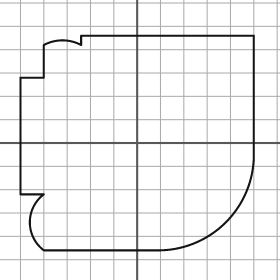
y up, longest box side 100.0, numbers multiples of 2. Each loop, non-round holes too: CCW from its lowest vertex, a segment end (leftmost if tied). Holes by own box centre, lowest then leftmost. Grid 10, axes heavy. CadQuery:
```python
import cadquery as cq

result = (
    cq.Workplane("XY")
    .moveTo(-40.0, -46.0)
    .lineTo(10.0, -46.0)
    .threePointArc((38.0, -34.0), (50.0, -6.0))
    .lineTo(50.0, 46.0)
    .lineTo(-24.0, 46.0)
    .lineTo(-24.0, 42.0)
    .threePointArc((-32.0, 44.0), (-40.0, 42.0))
    .lineTo(-40.0, 28.0)
    .lineTo(-50.0, 28.0)
    .lineTo(-50.0, -22.0)
    .lineTo(-40.0, -22.0)
    .threePointArc((-46.0, -34.0), (-40.0, -46.0))
    .close()
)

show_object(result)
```